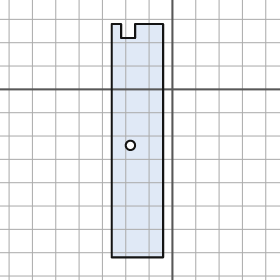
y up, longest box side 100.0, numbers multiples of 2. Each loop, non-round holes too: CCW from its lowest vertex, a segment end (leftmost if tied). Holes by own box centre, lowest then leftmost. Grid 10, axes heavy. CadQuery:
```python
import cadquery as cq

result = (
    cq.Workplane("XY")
    .moveTo(-26.0, -72.0)
    .lineTo(-4.0, -72.0)
    .lineTo(-4.0, 28.0)
    .lineTo(-16.0, 28.0)
    .lineTo(-16.0, 22.0)
    .lineTo(-22.0, 22.0)
    .lineTo(-22.0, 28.0)
    .lineTo(-26.0, 28.0)
    .close()
    .moveTo(-18.0, -24.0)
    .circle(2.0)
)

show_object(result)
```